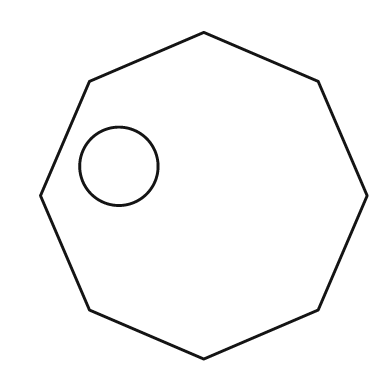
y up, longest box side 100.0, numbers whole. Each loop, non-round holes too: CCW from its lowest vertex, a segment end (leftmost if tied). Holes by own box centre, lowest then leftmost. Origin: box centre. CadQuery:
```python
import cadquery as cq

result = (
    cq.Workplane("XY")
    .moveTo(0.0, -50.0)
    .lineTo(35.0, -35.0)
    .lineTo(50.0, 0.0)
    .lineTo(35.0, 35.0)
    .lineTo(0.0, 50.0)
    .lineTo(-35.0, 35.0)
    .lineTo(-50.0, 0.0)
    .lineTo(-35.0, -35.0)
    .close()
    .moveTo(-26.0, 9.0)
    .circle(12.0)
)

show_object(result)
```